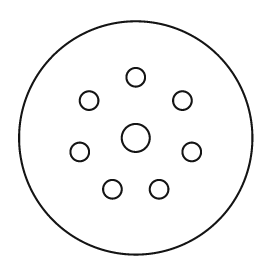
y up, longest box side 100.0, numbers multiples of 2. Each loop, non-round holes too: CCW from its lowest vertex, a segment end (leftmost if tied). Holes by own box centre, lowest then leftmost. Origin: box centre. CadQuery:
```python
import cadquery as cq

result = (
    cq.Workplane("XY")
    .moveTo(0.0, 0.0)
    .circle(50.0)
    .moveTo(-10.0, -22.0)
    .circle(4.0)
    .moveTo(10.0, -22.0)
    .circle(4.0)
    .moveTo(-24.0, -6.0)
    .circle(4.0)
    .moveTo(24.0, -6.0)
    .circle(4.0)
    .moveTo(0.0, 0.0)
    .circle(6.0)
    .moveTo(-20.0, 16.0)
    .circle(4.0)
    .moveTo(20.0, 16.0)
    .circle(4.0)
    .moveTo(0.0, 26.0)
    .circle(4.0)
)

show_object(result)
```